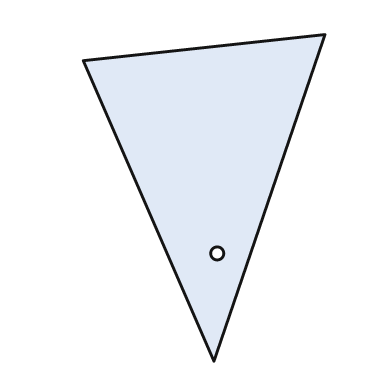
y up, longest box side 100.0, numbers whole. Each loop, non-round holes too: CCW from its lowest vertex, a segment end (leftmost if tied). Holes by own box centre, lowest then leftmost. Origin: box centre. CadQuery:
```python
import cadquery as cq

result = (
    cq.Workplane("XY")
    .moveTo(3.0, -50.0)
    .lineTo(37.0, 50.0)
    .lineTo(-37.0, 42.0)
    .close()
    .moveTo(4.0, -17.0)
    .circle(2.0)
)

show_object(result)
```